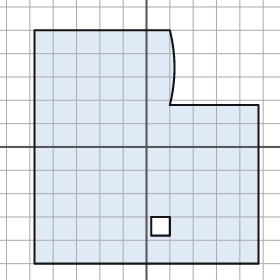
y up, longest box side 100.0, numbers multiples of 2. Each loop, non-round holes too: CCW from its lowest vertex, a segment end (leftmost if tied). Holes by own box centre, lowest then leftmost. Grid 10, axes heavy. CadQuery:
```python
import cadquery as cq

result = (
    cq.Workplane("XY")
    .moveTo(-48.0, -50.0)
    .lineTo(48.0, -50.0)
    .lineTo(48.0, 18.0)
    .lineTo(10.0, 18.0)
    .threePointArc((12.0, 34.0), (10.0, 50.0))
    .lineTo(-48.0, 50.0)
    .close()
    .moveTo(2.0, -38.0)
    .lineTo(10.0, -38.0)
    .lineTo(10.0, -30.0)
    .lineTo(2.0, -30.0)
    .close()
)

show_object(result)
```